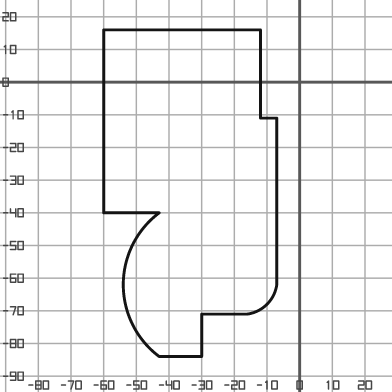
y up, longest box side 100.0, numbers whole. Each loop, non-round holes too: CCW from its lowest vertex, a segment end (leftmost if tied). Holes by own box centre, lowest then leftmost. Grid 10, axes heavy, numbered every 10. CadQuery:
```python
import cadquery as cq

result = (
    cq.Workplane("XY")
    .moveTo(-43.0, -84.0)
    .lineTo(-30.0, -84.0)
    .lineTo(-30.0, -71.0)
    .lineTo(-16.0, -71.0)
    .threePointArc((-10.0, -68.0), (-7.0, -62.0))
    .lineTo(-7.0, -11.0)
    .lineTo(-12.0, -11.0)
    .lineTo(-12.0, 16.0)
    .lineTo(-60.0, 16.0)
    .lineTo(-60.0, -40.0)
    .lineTo(-43.0, -40.0)
    .threePointArc((-54.0, -62.0), (-43.0, -84.0))
    .close()
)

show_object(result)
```